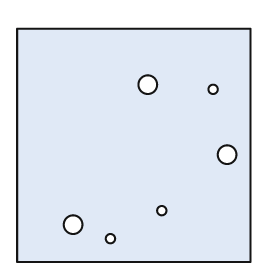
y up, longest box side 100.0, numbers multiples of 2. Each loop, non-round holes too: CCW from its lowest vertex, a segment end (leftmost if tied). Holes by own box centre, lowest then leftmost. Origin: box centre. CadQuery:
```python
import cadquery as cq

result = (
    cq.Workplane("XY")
    .moveTo(-50.0, -50.0)
    .lineTo(50.0, -50.0)
    .lineTo(50.0, 50.0)
    .lineTo(-50.0, 50.0)
    .close()
    .moveTo(-10.0, -40.0)
    .circle(2.0)
    .moveTo(-26.0, -34.0)
    .circle(4.0)
    .moveTo(12.0, -28.0)
    .circle(2.0)
    .moveTo(40.0, -4.0)
    .circle(4.0)
    .moveTo(34.0, 24.0)
    .circle(2.0)
    .moveTo(6.0, 26.0)
    .circle(4.0)
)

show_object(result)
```